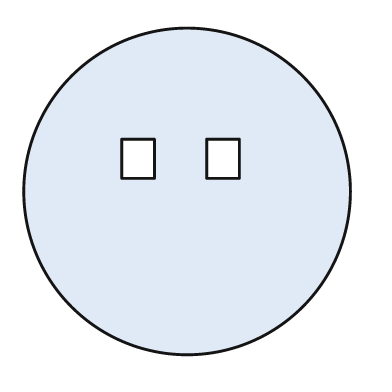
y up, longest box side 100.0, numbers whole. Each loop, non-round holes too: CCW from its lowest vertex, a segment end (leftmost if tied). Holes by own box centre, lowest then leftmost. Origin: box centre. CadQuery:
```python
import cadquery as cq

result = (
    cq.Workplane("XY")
    .moveTo(0.0, 0.0)
    .circle(50.0)
    .moveTo(-20.0, 4.0)
    .lineTo(-10.0, 4.0)
    .lineTo(-10.0, 16.0)
    .lineTo(-20.0, 16.0)
    .close()
    .moveTo(6.0, 4.0)
    .lineTo(16.0, 4.0)
    .lineTo(16.0, 16.0)
    .lineTo(6.0, 16.0)
    .close()
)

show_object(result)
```